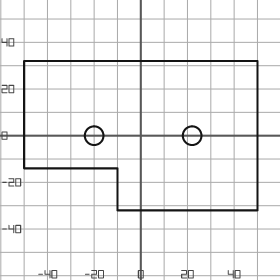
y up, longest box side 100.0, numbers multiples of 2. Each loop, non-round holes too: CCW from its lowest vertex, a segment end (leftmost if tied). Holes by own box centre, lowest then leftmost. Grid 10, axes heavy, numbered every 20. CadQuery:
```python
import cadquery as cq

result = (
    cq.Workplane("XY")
    .moveTo(-10.0, -32.0)
    .lineTo(50.0, -32.0)
    .lineTo(50.0, 32.0)
    .lineTo(-50.0, 32.0)
    .lineTo(-50.0, -14.0)
    .lineTo(-10.0, -14.0)
    .close()
    .moveTo(-20.0, 0.0)
    .circle(4.0)
    .moveTo(22.0, 0.0)
    .circle(4.0)
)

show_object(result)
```